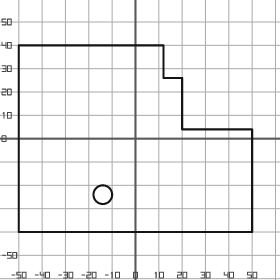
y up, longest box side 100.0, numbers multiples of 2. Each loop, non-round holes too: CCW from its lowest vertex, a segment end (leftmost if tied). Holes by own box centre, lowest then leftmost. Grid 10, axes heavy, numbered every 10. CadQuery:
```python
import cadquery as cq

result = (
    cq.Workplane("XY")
    .moveTo(-50.0, -40.0)
    .lineTo(50.0, -40.0)
    .lineTo(50.0, 4.0)
    .lineTo(20.0, 4.0)
    .lineTo(20.0, 26.0)
    .lineTo(12.0, 26.0)
    .lineTo(12.0, 40.0)
    .lineTo(-50.0, 40.0)
    .close()
    .moveTo(-14.0, -24.0)
    .circle(4.0)
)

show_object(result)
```